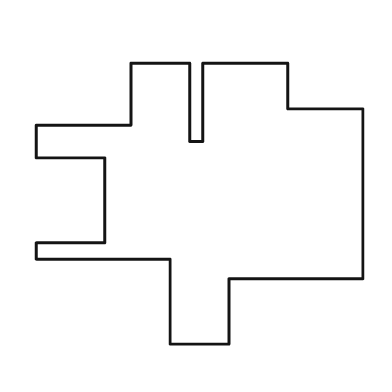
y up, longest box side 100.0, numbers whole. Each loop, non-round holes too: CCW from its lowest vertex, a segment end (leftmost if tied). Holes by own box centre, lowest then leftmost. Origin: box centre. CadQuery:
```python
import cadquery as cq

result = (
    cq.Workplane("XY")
    .moveTo(-9.0, -43.0)
    .lineTo(9.0, -43.0)
    .lineTo(9.0, -23.0)
    .lineTo(50.0, -23.0)
    .lineTo(50.0, 29.0)
    .lineTo(27.0, 29.0)
    .lineTo(27.0, 43.0)
    .lineTo(1.0, 43.0)
    .lineTo(1.0, 19.0)
    .lineTo(-3.0, 19.0)
    .lineTo(-3.0, 43.0)
    .lineTo(-21.0, 43.0)
    .lineTo(-21.0, 24.0)
    .lineTo(-50.0, 24.0)
    .lineTo(-50.0, 14.0)
    .lineTo(-29.0, 14.0)
    .lineTo(-29.0, -12.0)
    .lineTo(-50.0, -12.0)
    .lineTo(-50.0, -17.0)
    .lineTo(-9.0, -17.0)
    .close()
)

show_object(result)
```